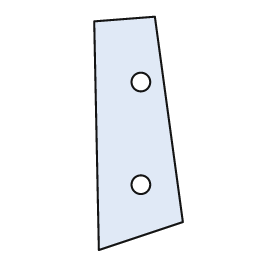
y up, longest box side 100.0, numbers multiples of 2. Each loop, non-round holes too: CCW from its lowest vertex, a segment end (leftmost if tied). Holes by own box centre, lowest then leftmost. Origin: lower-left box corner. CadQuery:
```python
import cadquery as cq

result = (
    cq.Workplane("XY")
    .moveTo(2.0, 0.0)
    .lineTo(38.0, 12.0)
    .lineTo(26.0, 100.0)
    .lineTo(0.0, 98.0)
    .close()
    .moveTo(20.0, 28.0)
    .circle(4.0)
    .moveTo(20.0, 72.0)
    .circle(4.0)
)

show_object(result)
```